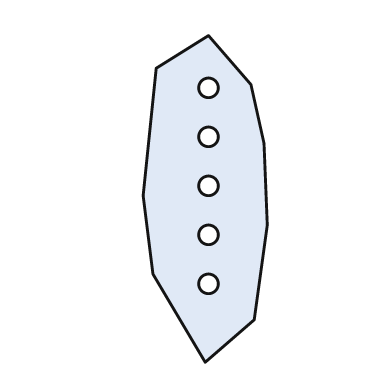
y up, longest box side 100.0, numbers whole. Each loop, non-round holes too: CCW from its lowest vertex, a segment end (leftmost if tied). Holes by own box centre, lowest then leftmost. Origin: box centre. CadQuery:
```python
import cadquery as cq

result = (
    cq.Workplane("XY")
    .moveTo(0.0, -50.0)
    .lineTo(15.0, -37.0)
    .lineTo(19.0, -8.0)
    .lineTo(18.0, 17.0)
    .lineTo(14.0, 35.0)
    .lineTo(1.0, 50.0)
    .lineTo(-15.0, 40.0)
    .lineTo(-19.0, 1.0)
    .lineTo(-16.0, -23.0)
    .close()
    .moveTo(1.0, -26.0)
    .circle(3.0)
    .moveTo(1.0, -11.0)
    .circle(3.0)
    .moveTo(1.0, 4.0)
    .circle(3.0)
    .moveTo(1.0, 19.0)
    .circle(3.0)
    .moveTo(1.0, 34.0)
    .circle(3.0)
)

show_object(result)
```